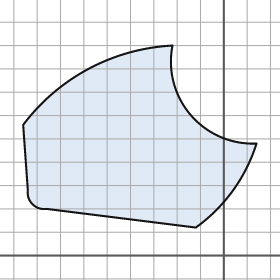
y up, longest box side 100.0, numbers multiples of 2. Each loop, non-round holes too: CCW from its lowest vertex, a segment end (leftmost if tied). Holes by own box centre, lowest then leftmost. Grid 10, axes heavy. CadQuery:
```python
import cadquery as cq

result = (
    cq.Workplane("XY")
    .moveTo(-12.0, 12.0)
    .threePointArc((4.0, 28.0), (14.0, 48.0))
    .threePointArc((-14.0, 60.0), (-22.0, 90.0))
    .threePointArc((-58.0, 80.0), (-86.0, 56.0))
    .lineTo(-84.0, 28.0)
    .threePointArc((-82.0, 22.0), (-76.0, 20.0))
    .close()
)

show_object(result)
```